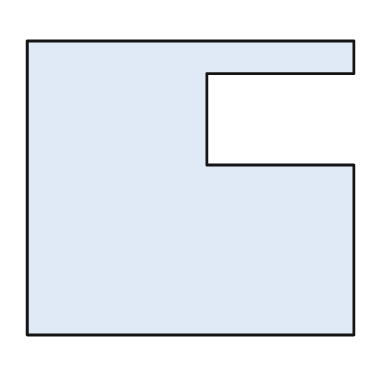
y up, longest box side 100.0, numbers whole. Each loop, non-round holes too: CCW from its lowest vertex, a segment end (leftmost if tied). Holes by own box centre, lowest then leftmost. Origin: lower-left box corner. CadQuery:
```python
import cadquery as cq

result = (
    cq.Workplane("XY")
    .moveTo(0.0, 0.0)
    .lineTo(100.0, 0.0)
    .lineTo(100.0, 52.0)
    .lineTo(55.0, 52.0)
    .lineTo(55.0, 80.0)
    .lineTo(100.0, 80.0)
    .lineTo(100.0, 90.0)
    .lineTo(0.0, 90.0)
    .close()
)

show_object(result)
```